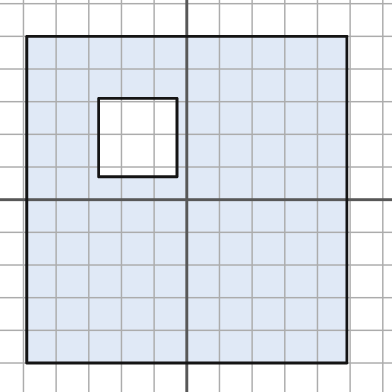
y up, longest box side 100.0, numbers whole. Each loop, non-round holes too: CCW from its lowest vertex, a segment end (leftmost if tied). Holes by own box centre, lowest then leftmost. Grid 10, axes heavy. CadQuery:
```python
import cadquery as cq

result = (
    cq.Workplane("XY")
    .moveTo(-49.0, -50.0)
    .lineTo(49.0, -50.0)
    .lineTo(49.0, 50.0)
    .lineTo(-49.0, 50.0)
    .close()
    .moveTo(-27.0, 7.0)
    .lineTo(-3.0, 7.0)
    .lineTo(-3.0, 31.0)
    .lineTo(-27.0, 31.0)
    .close()
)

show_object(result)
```